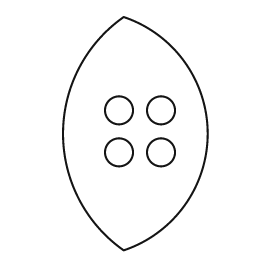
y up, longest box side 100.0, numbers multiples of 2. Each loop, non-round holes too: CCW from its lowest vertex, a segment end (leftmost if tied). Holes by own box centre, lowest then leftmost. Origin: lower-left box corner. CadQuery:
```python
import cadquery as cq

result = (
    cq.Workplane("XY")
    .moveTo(26.0, 0.0)
    .threePointArc((62.0, 50.0), (26.0, 100.0))
    .threePointArc((0.0, 50.0), (26.0, 0.0))
    .close()
    .moveTo(24.0, 42.0)
    .circle(6.0)
    .moveTo(42.0, 42.0)
    .circle(6.0)
    .moveTo(24.0, 60.0)
    .circle(6.0)
    .moveTo(42.0, 60.0)
    .circle(6.0)
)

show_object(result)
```